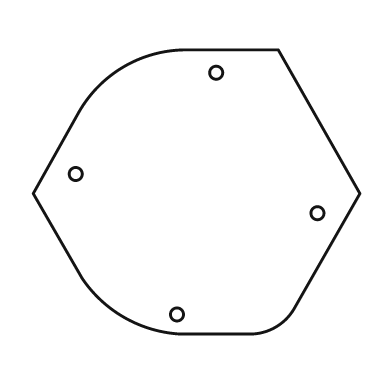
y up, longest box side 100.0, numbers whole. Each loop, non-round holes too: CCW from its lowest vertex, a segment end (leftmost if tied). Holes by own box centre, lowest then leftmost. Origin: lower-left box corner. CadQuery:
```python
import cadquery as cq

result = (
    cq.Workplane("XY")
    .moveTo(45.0, 0.0)
    .lineTo(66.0, 0.0)
    .threePointArc((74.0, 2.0), (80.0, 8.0))
    .lineTo(100.0, 43.0)
    .lineTo(75.0, 87.0)
    .lineTo(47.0, 87.0)
    .threePointArc((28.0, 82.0), (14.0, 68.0))
    .lineTo(0.0, 43.0)
    .lineTo(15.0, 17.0)
    .threePointArc((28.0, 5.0), (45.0, 0.0))
    .close()
    .moveTo(44.0, 6.0)
    .circle(2.0)
    .moveTo(87.0, 37.0)
    .circle(2.0)
    .moveTo(13.0, 49.0)
    .circle(2.0)
    .moveTo(56.0, 80.0)
    .circle(2.0)
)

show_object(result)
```